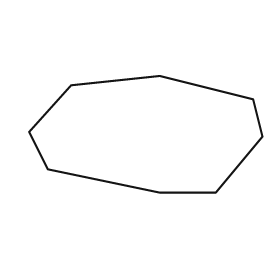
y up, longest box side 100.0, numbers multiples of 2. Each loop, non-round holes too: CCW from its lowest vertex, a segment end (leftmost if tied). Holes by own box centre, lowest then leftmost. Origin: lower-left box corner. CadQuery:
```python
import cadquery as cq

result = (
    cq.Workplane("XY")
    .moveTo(56.0, 0.0)
    .lineTo(80.0, 0.0)
    .lineTo(100.0, 24.0)
    .lineTo(96.0, 40.0)
    .lineTo(56.0, 50.0)
    .lineTo(18.0, 46.0)
    .lineTo(0.0, 26.0)
    .lineTo(8.0, 10.0)
    .close()
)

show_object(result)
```